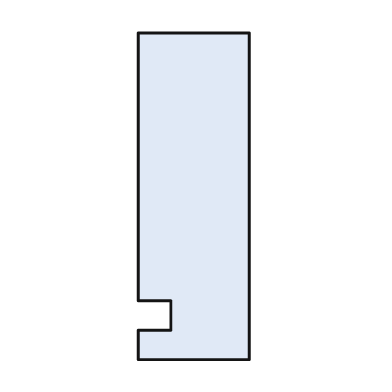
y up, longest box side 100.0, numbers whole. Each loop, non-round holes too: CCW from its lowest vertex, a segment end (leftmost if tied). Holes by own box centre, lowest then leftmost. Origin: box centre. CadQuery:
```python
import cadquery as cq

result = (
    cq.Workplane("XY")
    .moveTo(-17.0, -50.0)
    .lineTo(17.0, -50.0)
    .lineTo(17.0, 50.0)
    .lineTo(-17.0, 50.0)
    .lineTo(-17.0, -32.0)
    .lineTo(-7.0, -32.0)
    .lineTo(-7.0, -41.0)
    .lineTo(-17.0, -41.0)
    .close()
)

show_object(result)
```